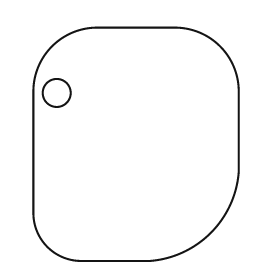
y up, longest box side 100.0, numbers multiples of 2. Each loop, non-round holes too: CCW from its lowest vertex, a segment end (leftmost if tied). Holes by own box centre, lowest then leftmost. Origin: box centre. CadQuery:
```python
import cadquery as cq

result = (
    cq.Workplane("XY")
    .moveTo(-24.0, -50.0)
    .lineTo(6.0, -50.0)
    .threePointArc((32.0, -38.0), (44.0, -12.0))
    .lineTo(44.0, 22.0)
    .threePointArc((36.0, 42.0), (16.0, 50.0))
    .lineTo(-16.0, 50.0)
    .threePointArc((-36.0, 42.0), (-44.0, 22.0))
    .lineTo(-44.0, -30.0)
    .threePointArc((-38.0, -44.0), (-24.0, -50.0))
    .close()
    .moveTo(-34.0, 22.0)
    .circle(6.0)
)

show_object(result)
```